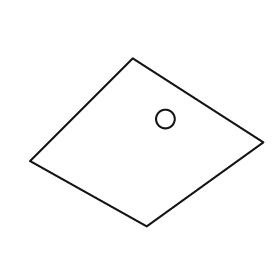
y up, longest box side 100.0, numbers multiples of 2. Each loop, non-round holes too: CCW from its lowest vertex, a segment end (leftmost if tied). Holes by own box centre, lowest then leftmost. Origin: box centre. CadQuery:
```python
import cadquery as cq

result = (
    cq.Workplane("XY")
    .moveTo(0.0, -36.0)
    .lineTo(50.0, 0.0)
    .lineTo(-6.0, 36.0)
    .lineTo(-50.0, -8.0)
    .close()
    .moveTo(8.0, 10.0)
    .circle(4.0)
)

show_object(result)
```